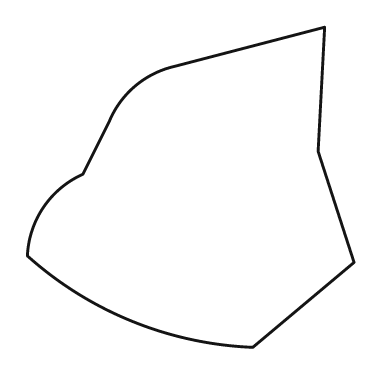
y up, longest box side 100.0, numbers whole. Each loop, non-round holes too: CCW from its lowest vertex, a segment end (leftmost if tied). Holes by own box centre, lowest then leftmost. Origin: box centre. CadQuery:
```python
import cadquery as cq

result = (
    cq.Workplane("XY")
    .moveTo(19.0, -49.0)
    .lineTo(50.0, -23.0)
    .lineTo(39.0, 11.0)
    .lineTo(41.0, 49.0)
    .lineTo(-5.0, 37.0)
    .threePointArc((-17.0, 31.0), (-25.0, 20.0))
    .lineTo(-33.0, 4.0)
    .threePointArc((-45.0, -6.0), (-50.0, -21.0))
    .threePointArc((-18.0, -41.0), (19.0, -49.0))
    .close()
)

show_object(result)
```